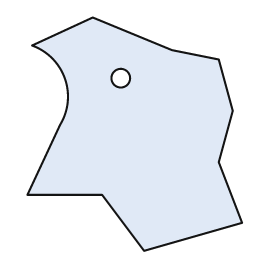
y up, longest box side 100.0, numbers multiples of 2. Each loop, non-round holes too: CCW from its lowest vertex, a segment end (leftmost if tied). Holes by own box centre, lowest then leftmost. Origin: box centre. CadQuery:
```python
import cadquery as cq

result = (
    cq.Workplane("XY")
    .moveTo(4.0, -50.0)
    .lineTo(46.0, -38.0)
    .lineTo(36.0, -12.0)
    .lineTo(42.0, 10.0)
    .lineTo(36.0, 32.0)
    .lineTo(16.0, 36.0)
    .lineTo(-18.0, 50.0)
    .lineTo(-44.0, 38.0)
    .threePointArc((-30.0, 24.0), (-32.0, 4.0))
    .lineTo(-46.0, -26.0)
    .lineTo(-14.0, -26.0)
    .close()
    .moveTo(-6.0, 24.0)
    .circle(4.0)
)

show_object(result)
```